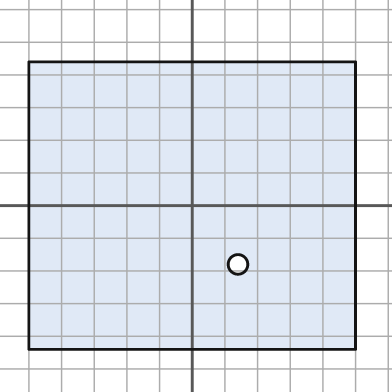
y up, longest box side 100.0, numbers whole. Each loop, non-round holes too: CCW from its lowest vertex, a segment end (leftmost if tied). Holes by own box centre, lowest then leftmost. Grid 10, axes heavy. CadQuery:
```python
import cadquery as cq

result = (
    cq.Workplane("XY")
    .moveTo(-50.0, -44.0)
    .lineTo(50.0, -44.0)
    .lineTo(50.0, 44.0)
    .lineTo(-50.0, 44.0)
    .close()
    .moveTo(14.0, -18.0)
    .circle(3.0)
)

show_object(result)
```